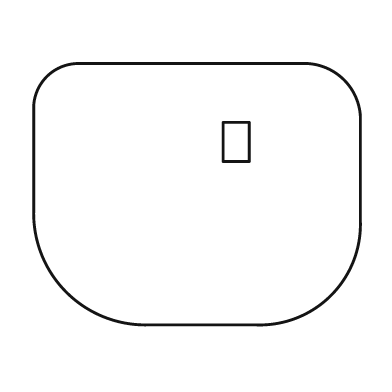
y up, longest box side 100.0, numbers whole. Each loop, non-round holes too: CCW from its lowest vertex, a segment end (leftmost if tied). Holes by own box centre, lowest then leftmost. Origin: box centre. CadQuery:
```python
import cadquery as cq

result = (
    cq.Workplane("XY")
    .moveTo(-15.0, -40.0)
    .lineTo(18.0, -40.0)
    .threePointArc((41.0, -31.0), (50.0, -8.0))
    .lineTo(50.0, 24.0)
    .threePointArc((45.0, 35.0), (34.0, 40.0))
    .lineTo(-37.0, 40.0)
    .threePointArc((-46.0, 36.0), (-50.0, 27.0))
    .lineTo(-50.0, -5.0)
    .threePointArc((-40.0, -30.0), (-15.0, -40.0))
    .close()
    .moveTo(8.0, 10.0)
    .lineTo(16.0, 10.0)
    .lineTo(16.0, 22.0)
    .lineTo(8.0, 22.0)
    .close()
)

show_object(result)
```